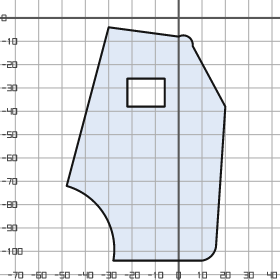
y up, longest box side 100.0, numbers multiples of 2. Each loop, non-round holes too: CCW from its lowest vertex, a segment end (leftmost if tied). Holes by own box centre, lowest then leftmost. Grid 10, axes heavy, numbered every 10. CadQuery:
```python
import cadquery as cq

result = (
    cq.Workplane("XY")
    .moveTo(-28.0, -104.0)
    .lineTo(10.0, -104.0)
    .threePointArc((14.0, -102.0), (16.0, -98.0))
    .lineTo(20.0, -38.0)
    .lineTo(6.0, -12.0)
    .threePointArc((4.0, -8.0), (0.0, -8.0))
    .lineTo(-30.0, -4.0)
    .lineTo(-48.0, -72.0)
    .threePointArc((-32.0, -84.0), (-28.0, -104.0))
    .close()
    .moveTo(-22.0, -38.0)
    .lineTo(-6.0, -38.0)
    .lineTo(-6.0, -26.0)
    .lineTo(-22.0, -26.0)
    .close()
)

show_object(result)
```